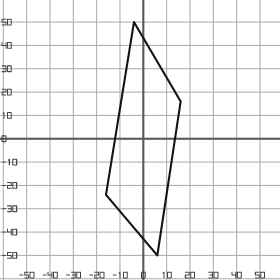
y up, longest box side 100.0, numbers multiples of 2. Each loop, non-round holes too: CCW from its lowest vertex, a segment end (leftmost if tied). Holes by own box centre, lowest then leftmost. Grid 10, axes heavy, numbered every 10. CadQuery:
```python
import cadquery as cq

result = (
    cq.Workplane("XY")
    .moveTo(6.0, -50.0)
    .lineTo(16.0, 16.0)
    .lineTo(-4.0, 50.0)
    .lineTo(-16.0, -24.0)
    .close()
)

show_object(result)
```